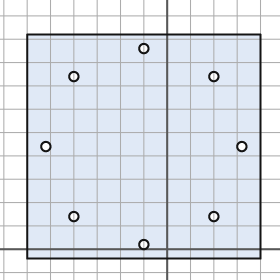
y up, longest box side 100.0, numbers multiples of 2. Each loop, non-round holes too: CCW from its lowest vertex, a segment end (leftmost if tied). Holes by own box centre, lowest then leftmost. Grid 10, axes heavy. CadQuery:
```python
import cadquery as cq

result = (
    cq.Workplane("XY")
    .moveTo(-60.0, -4.0)
    .lineTo(40.0, -4.0)
    .lineTo(40.0, 92.0)
    .lineTo(-60.0, 92.0)
    .close()
    .moveTo(-10.0, 2.0)
    .circle(2.0)
    .moveTo(-40.0, 14.0)
    .circle(2.0)
    .moveTo(20.0, 14.0)
    .circle(2.0)
    .moveTo(-52.0, 44.0)
    .circle(2.0)
    .moveTo(32.0, 44.0)
    .circle(2.0)
    .moveTo(-40.0, 74.0)
    .circle(2.0)
    .moveTo(20.0, 74.0)
    .circle(2.0)
    .moveTo(-10.0, 86.0)
    .circle(2.0)
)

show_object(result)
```